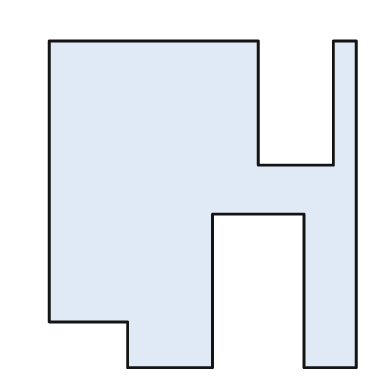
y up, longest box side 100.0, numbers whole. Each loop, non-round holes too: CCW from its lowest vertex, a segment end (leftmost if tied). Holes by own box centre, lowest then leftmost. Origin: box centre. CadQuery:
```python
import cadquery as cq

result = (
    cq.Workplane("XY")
    .moveTo(-23.0, -50.0)
    .lineTo(3.0, -50.0)
    .lineTo(3.0, -3.0)
    .lineTo(31.0, -3.0)
    .lineTo(31.0, -50.0)
    .lineTo(47.0, -50.0)
    .lineTo(47.0, 50.0)
    .lineTo(40.0, 50.0)
    .lineTo(40.0, 12.0)
    .lineTo(17.0, 12.0)
    .lineTo(17.0, 50.0)
    .lineTo(-47.0, 50.0)
    .lineTo(-47.0, -36.0)
    .lineTo(-23.0, -36.0)
    .close()
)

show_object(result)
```